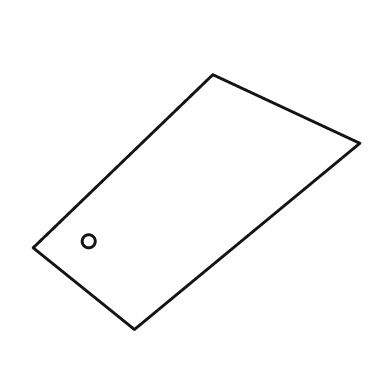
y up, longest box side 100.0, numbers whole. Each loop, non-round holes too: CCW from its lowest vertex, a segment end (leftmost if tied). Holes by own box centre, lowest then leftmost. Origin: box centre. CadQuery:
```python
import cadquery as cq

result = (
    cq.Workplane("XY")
    .moveTo(-19.0, -39.0)
    .lineTo(50.0, 18.0)
    .lineTo(5.0, 39.0)
    .lineTo(-50.0, -14.0)
    .close()
    .moveTo(-33.0, -12.0)
    .circle(2.0)
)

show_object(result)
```